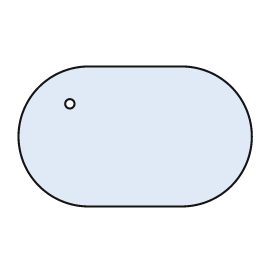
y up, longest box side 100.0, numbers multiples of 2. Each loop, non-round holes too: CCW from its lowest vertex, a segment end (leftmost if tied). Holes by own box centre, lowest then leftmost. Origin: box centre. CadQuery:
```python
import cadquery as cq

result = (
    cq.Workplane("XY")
    .moveTo(-20.0, -30.0)
    .lineTo(20.0, -30.0)
    .threePointArc((50.0, 0.0), (20.0, 30.0))
    .lineTo(-20.0, 30.0)
    .threePointArc((-50.0, 0.0), (-20.0, -30.0))
    .close()
    .moveTo(-28.0, 14.0)
    .circle(2.0)
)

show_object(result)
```